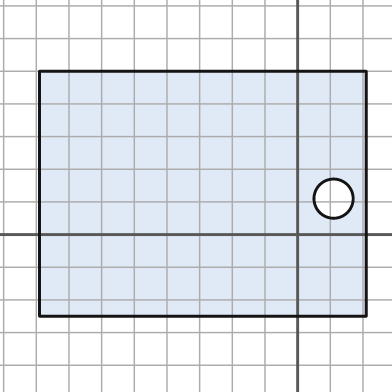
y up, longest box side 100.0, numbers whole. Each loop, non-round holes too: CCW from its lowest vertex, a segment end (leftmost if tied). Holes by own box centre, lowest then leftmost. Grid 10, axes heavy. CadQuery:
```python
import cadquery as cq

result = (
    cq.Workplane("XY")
    .moveTo(-79.0, -25.0)
    .lineTo(21.0, -25.0)
    .lineTo(21.0, 50.0)
    .lineTo(-79.0, 50.0)
    .close()
    .moveTo(11.0, 11.0)
    .circle(6.0)
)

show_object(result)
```